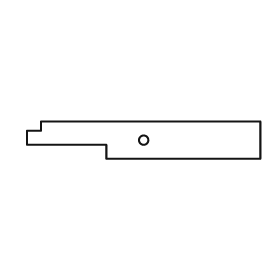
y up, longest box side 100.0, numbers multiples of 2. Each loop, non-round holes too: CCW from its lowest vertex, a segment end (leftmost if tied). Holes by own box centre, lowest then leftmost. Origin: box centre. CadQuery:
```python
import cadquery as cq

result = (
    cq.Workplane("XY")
    .moveTo(-16.0, -8.0)
    .lineTo(50.0, -8.0)
    .lineTo(50.0, 8.0)
    .lineTo(-44.0, 8.0)
    .lineTo(-44.0, 4.0)
    .lineTo(-50.0, 4.0)
    .lineTo(-50.0, -2.0)
    .lineTo(-16.0, -2.0)
    .close()
    .moveTo(0.0, 0.0)
    .circle(2.0)
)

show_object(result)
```